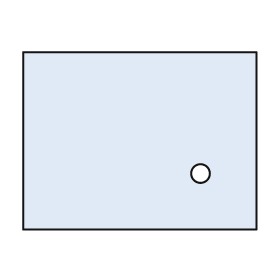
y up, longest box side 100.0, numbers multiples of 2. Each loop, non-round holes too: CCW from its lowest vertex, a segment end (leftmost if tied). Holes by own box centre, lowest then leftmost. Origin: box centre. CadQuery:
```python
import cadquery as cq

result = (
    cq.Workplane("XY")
    .moveTo(-50.0, -38.0)
    .lineTo(50.0, -38.0)
    .lineTo(50.0, 38.0)
    .lineTo(-50.0, 38.0)
    .close()
    .moveTo(26.0, -14.0)
    .circle(4.0)
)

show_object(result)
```